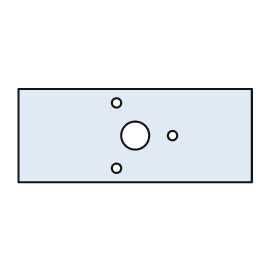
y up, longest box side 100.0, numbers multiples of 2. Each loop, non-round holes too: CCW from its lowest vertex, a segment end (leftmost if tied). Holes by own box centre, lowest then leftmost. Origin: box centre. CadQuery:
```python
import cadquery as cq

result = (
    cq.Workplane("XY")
    .moveTo(-50.0, -20.0)
    .lineTo(50.0, -20.0)
    .lineTo(50.0, 20.0)
    .lineTo(-50.0, 20.0)
    .close()
    .moveTo(-8.0, -14.0)
    .circle(2.0)
    .moveTo(0.0, 0.0)
    .circle(6.0)
    .moveTo(16.0, 0.0)
    .circle(2.0)
    .moveTo(-8.0, 14.0)
    .circle(2.0)
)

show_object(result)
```